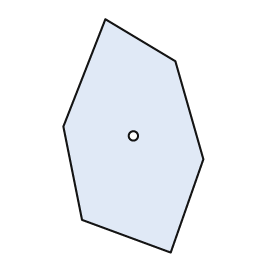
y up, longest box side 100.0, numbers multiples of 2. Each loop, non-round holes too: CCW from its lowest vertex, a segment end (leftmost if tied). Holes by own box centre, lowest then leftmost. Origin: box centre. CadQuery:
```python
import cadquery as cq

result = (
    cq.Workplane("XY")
    .moveTo(16.0, -50.0)
    .lineTo(30.0, -10.0)
    .lineTo(18.0, 32.0)
    .lineTo(-12.0, 50.0)
    .lineTo(-30.0, 4.0)
    .lineTo(-22.0, -36.0)
    .close()
    .moveTo(0.0, 0.0)
    .circle(2.0)
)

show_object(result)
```